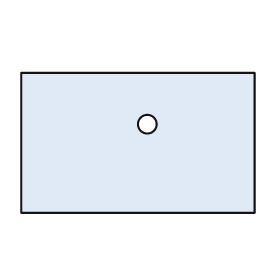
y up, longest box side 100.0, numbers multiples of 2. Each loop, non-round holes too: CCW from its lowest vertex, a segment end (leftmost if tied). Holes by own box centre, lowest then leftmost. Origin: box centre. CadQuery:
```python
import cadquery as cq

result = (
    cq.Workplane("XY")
    .moveTo(-50.0, -30.0)
    .lineTo(50.0, -30.0)
    .lineTo(50.0, 30.0)
    .lineTo(-50.0, 30.0)
    .close()
    .moveTo(4.0, 8.0)
    .circle(4.0)
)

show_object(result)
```